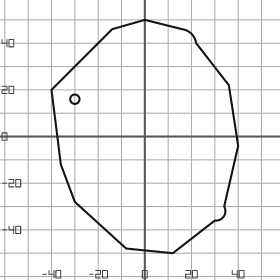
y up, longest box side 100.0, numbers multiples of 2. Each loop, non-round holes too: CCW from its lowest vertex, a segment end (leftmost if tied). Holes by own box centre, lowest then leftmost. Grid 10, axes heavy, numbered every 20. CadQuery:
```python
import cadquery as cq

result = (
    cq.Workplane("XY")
    .moveTo(12.0, -50.0)
    .lineTo(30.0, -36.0)
    .threePointArc((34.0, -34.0), (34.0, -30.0))
    .lineTo(40.0, -4.0)
    .lineTo(36.0, 22.0)
    .lineTo(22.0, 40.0)
    .threePointArc((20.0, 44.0), (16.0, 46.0))
    .lineTo(0.0, 50.0)
    .lineTo(-14.0, 46.0)
    .lineTo(-40.0, 20.0)
    .lineTo(-36.0, -12.0)
    .lineTo(-30.0, -28.0)
    .lineTo(-8.0, -48.0)
    .close()
    .moveTo(-30.0, 16.0)
    .circle(2.0)
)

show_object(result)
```